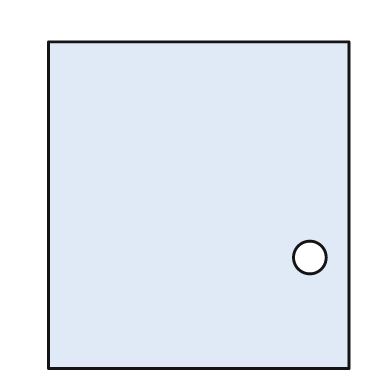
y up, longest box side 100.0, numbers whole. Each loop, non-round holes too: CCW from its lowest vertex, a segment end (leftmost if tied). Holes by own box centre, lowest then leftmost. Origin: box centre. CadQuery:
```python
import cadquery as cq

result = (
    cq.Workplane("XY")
    .moveTo(-46.0, -50.0)
    .lineTo(46.0, -50.0)
    .lineTo(46.0, 50.0)
    .lineTo(-46.0, 50.0)
    .close()
    .moveTo(34.0, -16.0)
    .circle(5.0)
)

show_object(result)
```